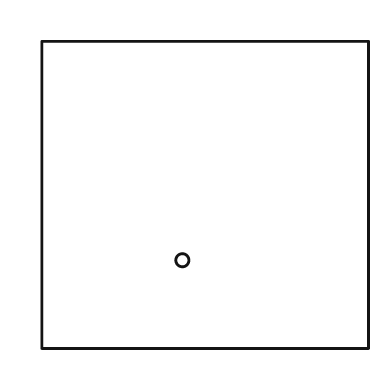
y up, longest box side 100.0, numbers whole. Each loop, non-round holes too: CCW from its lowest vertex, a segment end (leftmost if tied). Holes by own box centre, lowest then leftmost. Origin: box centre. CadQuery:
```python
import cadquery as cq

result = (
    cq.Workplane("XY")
    .moveTo(-50.0, -47.0)
    .lineTo(50.0, -47.0)
    .lineTo(50.0, 47.0)
    .lineTo(-50.0, 47.0)
    .close()
    .moveTo(-7.0, -20.0)
    .circle(2.0)
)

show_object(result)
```